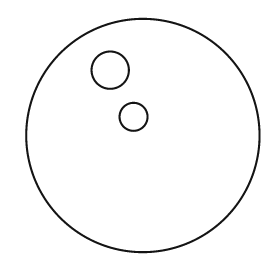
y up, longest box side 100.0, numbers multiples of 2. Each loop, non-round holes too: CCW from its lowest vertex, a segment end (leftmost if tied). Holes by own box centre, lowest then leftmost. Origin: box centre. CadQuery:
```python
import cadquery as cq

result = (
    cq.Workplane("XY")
    .moveTo(0.0, 0.0)
    .circle(50.0)
    .moveTo(-4.0, 8.0)
    .circle(6.0)
    .moveTo(-14.0, 28.0)
    .circle(8.0)
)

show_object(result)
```